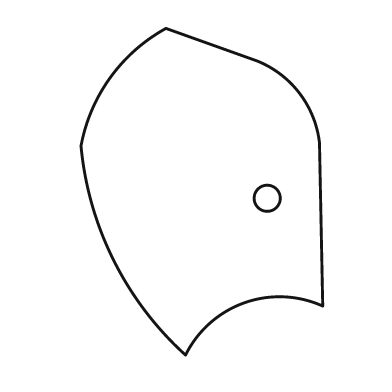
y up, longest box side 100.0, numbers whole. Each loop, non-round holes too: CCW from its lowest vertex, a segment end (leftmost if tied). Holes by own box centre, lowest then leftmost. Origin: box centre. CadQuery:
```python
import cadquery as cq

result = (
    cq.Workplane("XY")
    .moveTo(-5.0, -50.0)
    .threePointArc((13.0, -34.0), (37.0, -35.0))
    .lineTo(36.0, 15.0)
    .threePointArc((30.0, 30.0), (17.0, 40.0))
    .lineTo(-11.0, 50.0)
    .threePointArc((-28.0, 35.0), (-37.0, 14.0))
    .threePointArc((-27.0, -21.0), (-5.0, -50.0))
    .close()
    .moveTo(20.0, -2.0)
    .circle(4.0)
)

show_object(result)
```